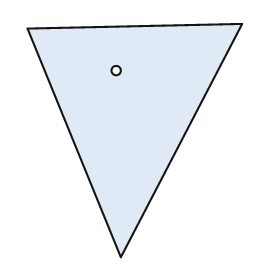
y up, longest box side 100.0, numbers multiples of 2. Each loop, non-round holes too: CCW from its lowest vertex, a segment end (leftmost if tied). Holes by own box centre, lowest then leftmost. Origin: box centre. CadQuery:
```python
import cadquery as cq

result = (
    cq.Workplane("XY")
    .moveTo(-6.0, -50.0)
    .lineTo(46.0, 50.0)
    .lineTo(-46.0, 48.0)
    .close()
    .moveTo(-8.0, 30.0)
    .circle(2.0)
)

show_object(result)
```